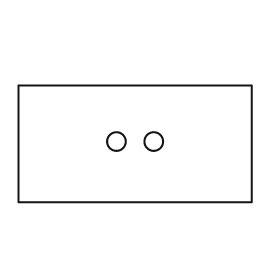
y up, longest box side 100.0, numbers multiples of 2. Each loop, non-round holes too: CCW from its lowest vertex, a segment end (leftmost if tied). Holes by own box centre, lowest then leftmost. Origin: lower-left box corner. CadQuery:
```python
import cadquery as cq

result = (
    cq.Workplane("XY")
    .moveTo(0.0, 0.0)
    .lineTo(100.0, 0.0)
    .lineTo(100.0, 50.0)
    .lineTo(0.0, 50.0)
    .close()
    .moveTo(42.0, 26.0)
    .circle(4.0)
    .moveTo(58.0, 26.0)
    .circle(4.0)
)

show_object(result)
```